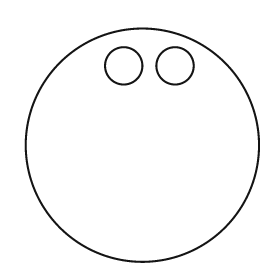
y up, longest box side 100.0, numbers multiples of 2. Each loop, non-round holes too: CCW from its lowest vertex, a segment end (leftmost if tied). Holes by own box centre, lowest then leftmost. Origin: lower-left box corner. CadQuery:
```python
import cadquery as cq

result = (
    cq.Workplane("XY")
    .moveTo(50.0, 50.0)
    .circle(50.0)
    .moveTo(42.0, 84.0)
    .circle(8.0)
    .moveTo(64.0, 84.0)
    .circle(8.0)
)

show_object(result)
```